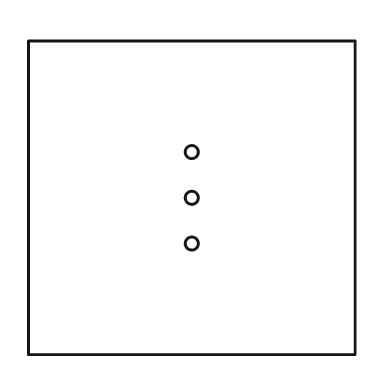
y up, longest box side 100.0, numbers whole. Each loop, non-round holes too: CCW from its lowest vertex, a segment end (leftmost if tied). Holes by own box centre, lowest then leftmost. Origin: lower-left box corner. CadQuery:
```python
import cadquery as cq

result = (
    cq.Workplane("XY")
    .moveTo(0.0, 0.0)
    .lineTo(100.0, 0.0)
    .lineTo(100.0, 96.0)
    .lineTo(0.0, 96.0)
    .close()
    .moveTo(50.0, 34.0)
    .circle(2.0)
    .moveTo(50.0, 48.0)
    .circle(2.0)
    .moveTo(50.0, 62.0)
    .circle(2.0)
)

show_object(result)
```